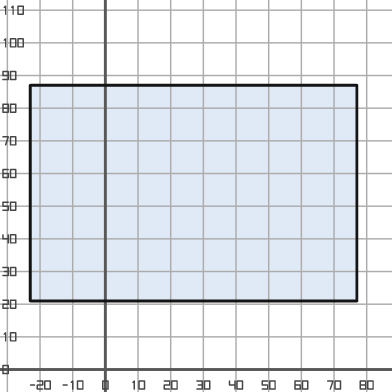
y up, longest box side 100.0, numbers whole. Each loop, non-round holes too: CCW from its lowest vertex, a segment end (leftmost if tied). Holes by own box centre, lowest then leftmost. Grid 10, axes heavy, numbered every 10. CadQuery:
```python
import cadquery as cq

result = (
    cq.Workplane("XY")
    .moveTo(-23.0, 21.0)
    .lineTo(77.0, 21.0)
    .lineTo(77.0, 87.0)
    .lineTo(-23.0, 87.0)
    .close()
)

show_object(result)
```